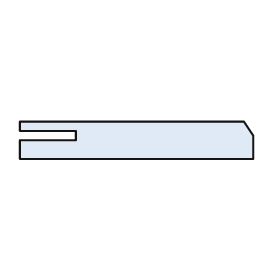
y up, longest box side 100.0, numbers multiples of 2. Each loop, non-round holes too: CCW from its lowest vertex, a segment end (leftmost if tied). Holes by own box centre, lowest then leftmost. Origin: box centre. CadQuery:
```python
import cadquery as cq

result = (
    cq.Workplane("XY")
    .moveTo(-50.0, -8.0)
    .lineTo(50.0, -8.0)
    .lineTo(50.0, 2.0)
    .lineTo(46.0, 8.0)
    .lineTo(-50.0, 8.0)
    .lineTo(-50.0, 4.0)
    .lineTo(-26.0, 4.0)
    .lineTo(-26.0, 0.0)
    .lineTo(-50.0, 0.0)
    .close()
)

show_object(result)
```